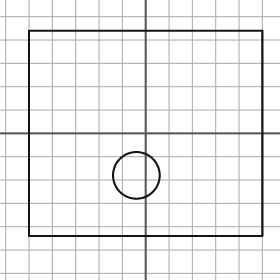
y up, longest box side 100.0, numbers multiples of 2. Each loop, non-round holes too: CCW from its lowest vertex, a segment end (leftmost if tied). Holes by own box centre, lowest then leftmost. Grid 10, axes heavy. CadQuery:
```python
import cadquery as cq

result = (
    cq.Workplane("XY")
    .moveTo(-50.0, -44.0)
    .lineTo(50.0, -44.0)
    .lineTo(50.0, 44.0)
    .lineTo(-50.0, 44.0)
    .close()
    .moveTo(-4.0, -18.0)
    .circle(10.0)
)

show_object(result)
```